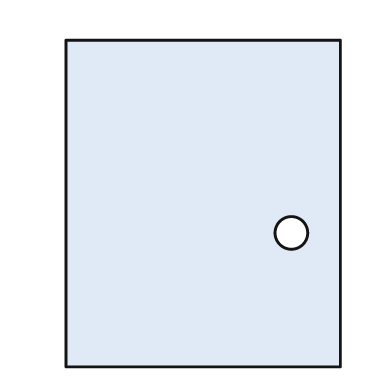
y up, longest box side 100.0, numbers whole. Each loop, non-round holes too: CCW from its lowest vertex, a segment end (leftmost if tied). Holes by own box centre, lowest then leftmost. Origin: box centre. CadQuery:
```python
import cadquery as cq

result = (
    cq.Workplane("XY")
    .moveTo(-42.0, -50.0)
    .lineTo(42.0, -50.0)
    .lineTo(42.0, 50.0)
    .lineTo(-42.0, 50.0)
    .close()
    .moveTo(27.0, -9.0)
    .circle(5.0)
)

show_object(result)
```